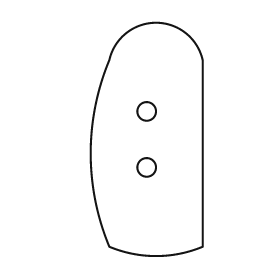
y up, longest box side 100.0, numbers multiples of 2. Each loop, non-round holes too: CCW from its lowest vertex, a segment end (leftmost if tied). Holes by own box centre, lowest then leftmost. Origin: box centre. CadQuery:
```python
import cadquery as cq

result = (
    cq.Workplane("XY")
    .moveTo(-16.0, -46.0)
    .threePointArc((4.0, -50.0), (24.0, -46.0))
    .lineTo(24.0, 34.0)
    .threePointArc((4.0, 50.0), (-16.0, 34.0))
    .threePointArc((-24.0, -6.0), (-16.0, -46.0))
    .close()
    .moveTo(0.0, -12.0)
    .circle(4.0)
    .moveTo(0.0, 12.0)
    .circle(4.0)
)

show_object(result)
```